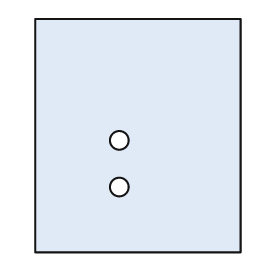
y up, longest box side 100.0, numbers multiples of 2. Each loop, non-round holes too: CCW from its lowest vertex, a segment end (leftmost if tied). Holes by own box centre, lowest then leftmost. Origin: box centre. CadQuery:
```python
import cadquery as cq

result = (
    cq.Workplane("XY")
    .moveTo(-44.0, -50.0)
    .lineTo(44.0, -50.0)
    .lineTo(44.0, 50.0)
    .lineTo(-44.0, 50.0)
    .close()
    .moveTo(-8.0, -22.0)
    .circle(4.0)
    .moveTo(-8.0, -2.0)
    .circle(4.0)
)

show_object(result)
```